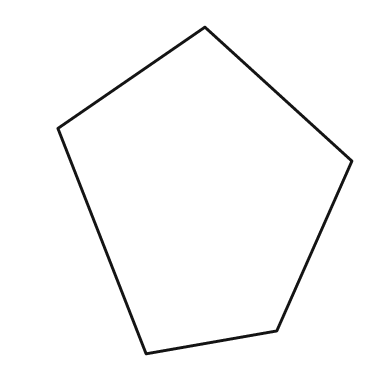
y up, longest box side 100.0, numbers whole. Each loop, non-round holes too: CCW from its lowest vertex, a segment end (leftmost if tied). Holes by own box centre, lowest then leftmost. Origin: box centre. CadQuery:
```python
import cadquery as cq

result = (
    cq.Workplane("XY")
    .moveTo(-18.0, -50.0)
    .lineTo(22.0, -43.0)
    .lineTo(45.0, 9.0)
    .lineTo(0.0, 50.0)
    .lineTo(-45.0, 19.0)
    .close()
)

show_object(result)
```